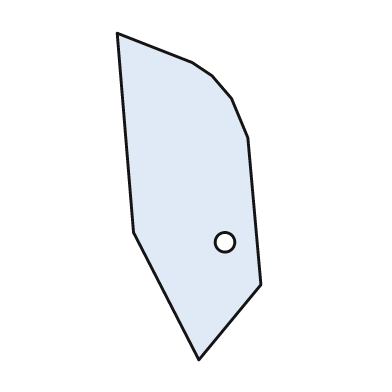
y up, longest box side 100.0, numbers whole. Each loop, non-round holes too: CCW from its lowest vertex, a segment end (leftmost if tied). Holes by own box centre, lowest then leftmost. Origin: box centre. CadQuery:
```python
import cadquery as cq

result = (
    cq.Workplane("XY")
    .moveTo(3.0, -50.0)
    .lineTo(22.0, -27.0)
    .lineTo(18.0, 18.0)
    .lineTo(13.0, 30.0)
    .lineTo(7.0, 37.0)
    .lineTo(1.0, 41.0)
    .lineTo(-22.0, 50.0)
    .lineTo(-17.0, -11.0)
    .close()
    .moveTo(11.0, -14.0)
    .circle(3.0)
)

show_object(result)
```